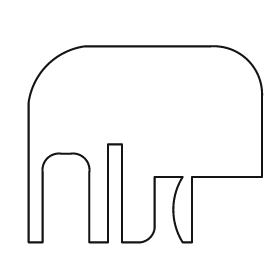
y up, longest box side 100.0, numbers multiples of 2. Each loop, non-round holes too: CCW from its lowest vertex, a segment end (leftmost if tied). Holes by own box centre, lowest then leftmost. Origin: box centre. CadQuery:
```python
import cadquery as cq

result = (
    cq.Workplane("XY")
    .moveTo(-50.0, -42.0)
    .lineTo(-44.0, -42.0)
    .lineTo(-44.0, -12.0)
    .threePointArc((-42.0, -6.0), (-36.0, -4.0))
    .lineTo(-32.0, -4.0)
    .threePointArc((-26.0, -6.0), (-24.0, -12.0))
    .lineTo(-24.0, -42.0)
    .lineTo(-16.0, -42.0)
    .lineTo(-16.0, 0.0)
    .lineTo(-10.0, 0.0)
    .lineTo(-10.0, -42.0)
    .lineTo(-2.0, -42.0)
    .threePointArc((2.0, -40.0), (4.0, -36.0))
    .lineTo(4.0, -14.0)
    .lineTo(16.0, -14.0)
    .threePointArc((12.0, -28.0), (16.0, -42.0))
    .lineTo(20.0, -42.0)
    .lineTo(20.0, -14.0)
    .lineTo(50.0, -14.0)
    .lineTo(50.0, 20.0)
    .threePointArc((44.0, 36.0), (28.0, 42.0))
    .lineTo(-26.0, 42.0)
    .threePointArc((-42.0, 34.0), (-50.0, 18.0))
    .close()
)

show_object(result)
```